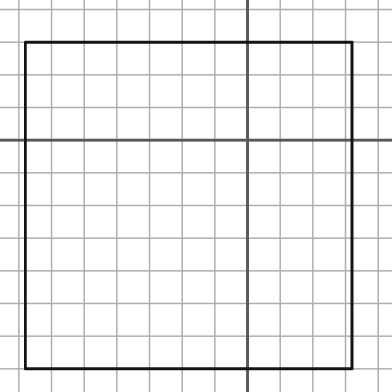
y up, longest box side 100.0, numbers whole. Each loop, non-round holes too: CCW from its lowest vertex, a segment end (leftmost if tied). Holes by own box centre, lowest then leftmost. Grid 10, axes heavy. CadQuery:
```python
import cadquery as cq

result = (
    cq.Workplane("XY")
    .moveTo(-68.0, -70.0)
    .lineTo(32.0, -70.0)
    .lineTo(32.0, 30.0)
    .lineTo(-68.0, 30.0)
    .close()
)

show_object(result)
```